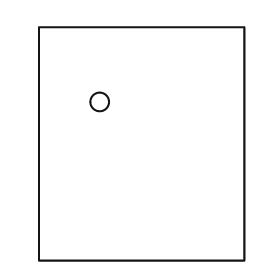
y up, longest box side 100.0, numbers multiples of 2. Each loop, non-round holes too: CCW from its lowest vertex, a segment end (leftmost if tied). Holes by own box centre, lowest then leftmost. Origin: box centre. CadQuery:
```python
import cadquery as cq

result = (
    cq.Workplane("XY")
    .moveTo(-44.0, -50.0)
    .lineTo(44.0, -50.0)
    .lineTo(44.0, 50.0)
    .lineTo(-44.0, 50.0)
    .close()
    .moveTo(-18.0, 18.0)
    .circle(4.0)
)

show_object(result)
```